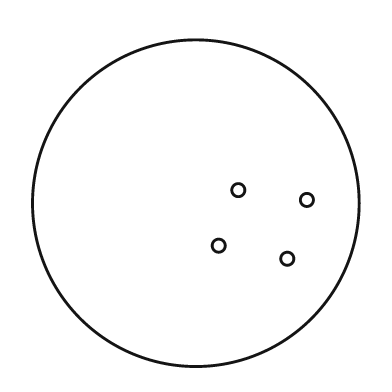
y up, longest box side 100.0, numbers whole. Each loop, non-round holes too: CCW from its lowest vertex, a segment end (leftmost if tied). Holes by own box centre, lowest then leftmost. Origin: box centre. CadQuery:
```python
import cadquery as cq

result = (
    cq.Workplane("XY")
    .moveTo(0.0, 0.0)
    .circle(50.0)
    .moveTo(28.0, -17.0)
    .circle(2.0)
    .moveTo(7.0, -13.0)
    .circle(2.0)
    .moveTo(34.0, 1.0)
    .circle(2.0)
    .moveTo(13.0, 4.0)
    .circle(2.0)
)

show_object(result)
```